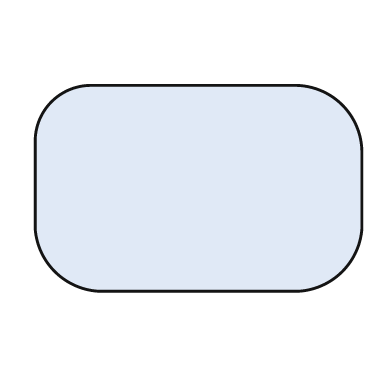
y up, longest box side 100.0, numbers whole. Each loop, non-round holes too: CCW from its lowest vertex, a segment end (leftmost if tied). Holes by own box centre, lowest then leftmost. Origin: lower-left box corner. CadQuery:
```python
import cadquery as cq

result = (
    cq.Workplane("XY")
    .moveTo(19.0, 0.0)
    .lineTo(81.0, 0.0)
    .threePointArc((94.0, 6.0), (100.0, 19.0))
    .lineTo(100.0, 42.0)
    .threePointArc((94.0, 57.0), (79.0, 63.0))
    .lineTo(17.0, 63.0)
    .threePointArc((5.0, 58.0), (0.0, 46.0))
    .lineTo(0.0, 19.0)
    .threePointArc((6.0, 6.0), (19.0, 0.0))
    .close()
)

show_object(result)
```